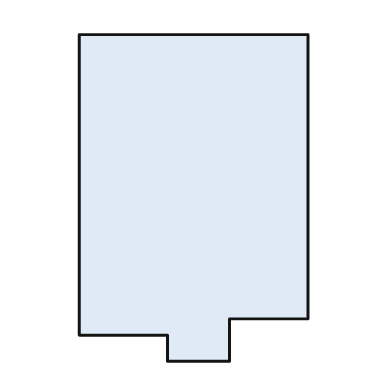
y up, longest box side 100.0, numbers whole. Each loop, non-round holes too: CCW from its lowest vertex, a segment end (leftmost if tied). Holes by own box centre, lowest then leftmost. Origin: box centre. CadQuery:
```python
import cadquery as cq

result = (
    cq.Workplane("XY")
    .moveTo(-8.0, -50.0)
    .lineTo(11.0, -50.0)
    .lineTo(11.0, -37.0)
    .lineTo(35.0, -37.0)
    .lineTo(35.0, 50.0)
    .lineTo(-35.0, 50.0)
    .lineTo(-35.0, -42.0)
    .lineTo(-8.0, -42.0)
    .close()
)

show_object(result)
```